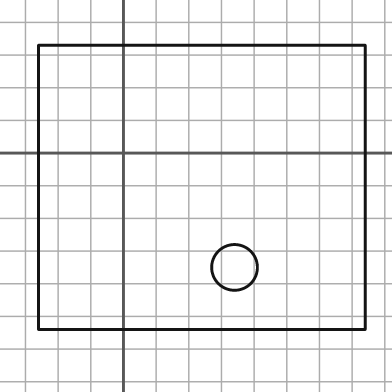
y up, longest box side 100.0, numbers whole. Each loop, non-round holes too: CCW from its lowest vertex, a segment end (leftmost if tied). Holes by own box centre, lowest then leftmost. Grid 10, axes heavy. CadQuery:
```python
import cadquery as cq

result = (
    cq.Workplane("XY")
    .moveTo(-26.0, -54.0)
    .lineTo(74.0, -54.0)
    .lineTo(74.0, 33.0)
    .lineTo(-26.0, 33.0)
    .close()
    .moveTo(34.0, -35.0)
    .circle(7.0)
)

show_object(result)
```